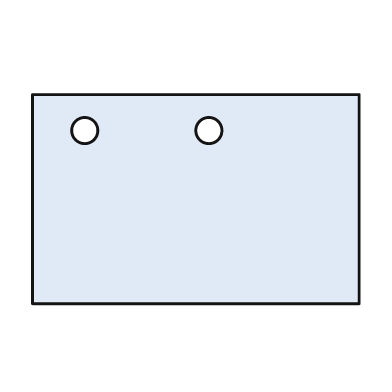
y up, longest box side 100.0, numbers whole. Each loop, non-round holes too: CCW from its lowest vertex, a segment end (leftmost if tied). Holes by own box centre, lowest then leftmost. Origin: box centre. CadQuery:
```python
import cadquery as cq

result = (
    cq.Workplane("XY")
    .moveTo(-50.0, -32.0)
    .lineTo(50.0, -32.0)
    .lineTo(50.0, 32.0)
    .lineTo(-50.0, 32.0)
    .close()
    .moveTo(-34.0, 21.0)
    .circle(4.0)
    .moveTo(4.0, 21.0)
    .circle(4.0)
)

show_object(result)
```